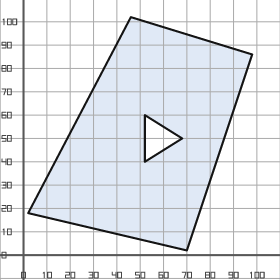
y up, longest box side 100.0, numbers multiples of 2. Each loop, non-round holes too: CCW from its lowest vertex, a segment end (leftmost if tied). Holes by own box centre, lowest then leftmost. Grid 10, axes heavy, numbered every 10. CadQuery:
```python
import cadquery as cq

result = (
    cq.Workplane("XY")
    .moveTo(70.0, 2.0)
    .lineTo(98.0, 86.0)
    .lineTo(46.0, 102.0)
    .lineTo(2.0, 18.0)
    .close()
    .moveTo(52.0, 40.0)
    .lineTo(68.0, 50.0)
    .lineTo(52.0, 60.0)
    .close()
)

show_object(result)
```